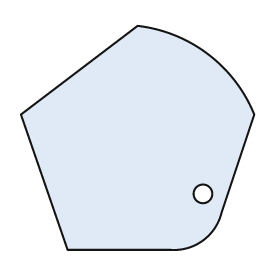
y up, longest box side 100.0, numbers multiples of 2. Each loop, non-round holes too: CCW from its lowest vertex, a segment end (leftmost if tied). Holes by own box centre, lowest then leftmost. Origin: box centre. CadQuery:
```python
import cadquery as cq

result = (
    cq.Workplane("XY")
    .moveTo(-30.0, -48.0)
    .lineTo(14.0, -48.0)
    .threePointArc((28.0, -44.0), (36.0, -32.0))
    .lineTo(50.0, 10.0)
    .threePointArc((30.0, 36.0), (0.0, 48.0))
    .lineTo(-50.0, 10.0)
    .close()
    .moveTo(28.0, -24.0)
    .circle(4.0)
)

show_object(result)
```